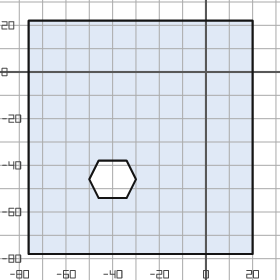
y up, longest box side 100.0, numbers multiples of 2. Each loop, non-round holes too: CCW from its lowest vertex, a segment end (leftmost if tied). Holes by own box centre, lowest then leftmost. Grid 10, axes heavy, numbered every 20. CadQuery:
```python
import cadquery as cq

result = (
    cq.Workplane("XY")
    .moveTo(-76.0, -78.0)
    .lineTo(20.0, -78.0)
    .lineTo(20.0, 22.0)
    .lineTo(-76.0, 22.0)
    .close()
    .moveTo(-46.0, -54.0)
    .lineTo(-34.0, -54.0)
    .lineTo(-30.0, -46.0)
    .lineTo(-34.0, -38.0)
    .lineTo(-46.0, -38.0)
    .lineTo(-50.0, -46.0)
    .close()
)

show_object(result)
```